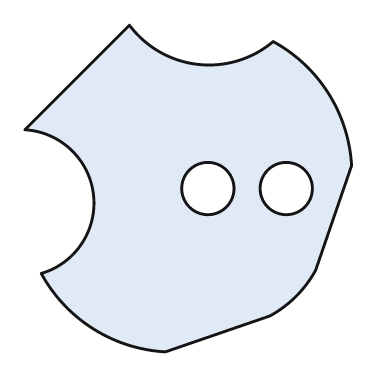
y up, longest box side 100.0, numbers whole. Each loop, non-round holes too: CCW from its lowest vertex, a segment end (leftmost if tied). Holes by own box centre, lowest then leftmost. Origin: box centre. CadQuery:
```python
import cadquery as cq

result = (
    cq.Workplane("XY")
    .moveTo(-7.0, -50.0)
    .lineTo(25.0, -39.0)
    .threePointArc((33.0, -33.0), (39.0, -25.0))
    .lineTo(50.0, 7.0)
    .threePointArc((43.0, 29.0), (26.0, 45.0))
    .threePointArc((3.0, 38.0), (-18.0, 50.0))
    .lineTo(-50.0, 18.0)
    .threePointArc((-29.0, -2.0), (-45.0, -26.0))
    .threePointArc((-29.0, -43.0), (-7.0, -50.0))
    .close()
    .moveTo(6.0, 0.0)
    .circle(8.0)
    .moveTo(30.0, 0.0)
    .circle(8.0)
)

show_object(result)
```